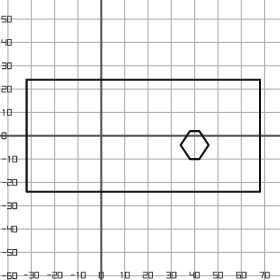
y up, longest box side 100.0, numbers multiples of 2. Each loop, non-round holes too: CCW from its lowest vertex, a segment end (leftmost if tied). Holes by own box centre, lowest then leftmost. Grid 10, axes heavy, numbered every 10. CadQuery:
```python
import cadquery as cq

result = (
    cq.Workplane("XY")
    .moveTo(-32.0, -24.0)
    .lineTo(68.0, -24.0)
    .lineTo(68.0, 24.0)
    .lineTo(-32.0, 24.0)
    .close()
    .moveTo(38.0, -10.0)
    .lineTo(42.0, -10.0)
    .lineTo(46.0, -4.0)
    .lineTo(42.0, 2.0)
    .lineTo(38.0, 2.0)
    .lineTo(34.0, -4.0)
    .close()
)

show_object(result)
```